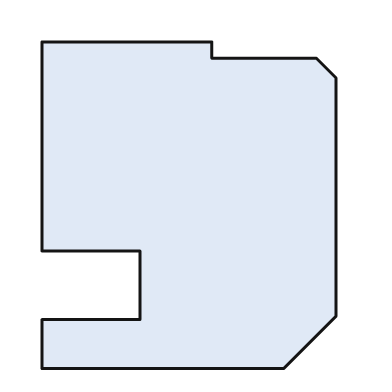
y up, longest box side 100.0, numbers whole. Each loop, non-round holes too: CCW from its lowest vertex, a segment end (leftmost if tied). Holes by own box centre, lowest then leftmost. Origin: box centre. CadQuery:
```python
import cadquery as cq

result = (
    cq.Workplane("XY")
    .moveTo(-45.0, -50.0)
    .lineTo(29.0, -50.0)
    .lineTo(45.0, -34.0)
    .lineTo(45.0, 39.0)
    .lineTo(39.0, 45.0)
    .lineTo(7.0, 45.0)
    .lineTo(7.0, 50.0)
    .lineTo(-45.0, 50.0)
    .lineTo(-45.0, -14.0)
    .lineTo(-15.0, -14.0)
    .lineTo(-15.0, -35.0)
    .lineTo(-45.0, -35.0)
    .close()
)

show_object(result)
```